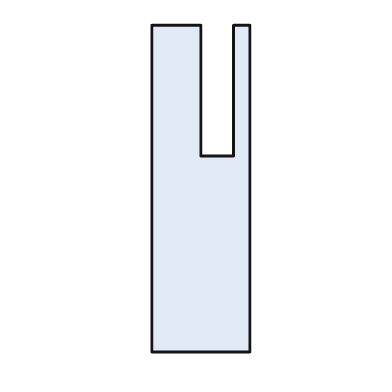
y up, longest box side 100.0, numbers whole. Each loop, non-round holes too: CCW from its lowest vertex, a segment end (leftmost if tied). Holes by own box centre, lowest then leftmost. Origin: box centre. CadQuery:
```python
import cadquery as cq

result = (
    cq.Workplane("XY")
    .moveTo(-15.0, -50.0)
    .lineTo(15.0, -50.0)
    .lineTo(15.0, 50.0)
    .lineTo(10.0, 50.0)
    .lineTo(10.0, 10.0)
    .lineTo(0.0, 10.0)
    .lineTo(0.0, 50.0)
    .lineTo(-15.0, 50.0)
    .close()
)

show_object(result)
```